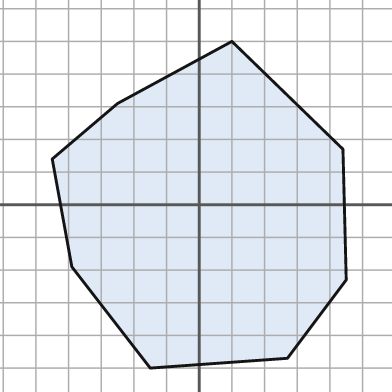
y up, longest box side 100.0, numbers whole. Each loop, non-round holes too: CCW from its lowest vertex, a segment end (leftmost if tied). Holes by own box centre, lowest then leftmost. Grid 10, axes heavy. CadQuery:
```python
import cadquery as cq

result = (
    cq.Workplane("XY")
    .moveTo(-15.0, -50.0)
    .lineTo(27.0, -47.0)
    .lineTo(45.0, -23.0)
    .lineTo(44.0, 17.0)
    .lineTo(10.0, 50.0)
    .lineTo(-25.0, 31.0)
    .lineTo(-45.0, 14.0)
    .lineTo(-39.0, -19.0)
    .close()
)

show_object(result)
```